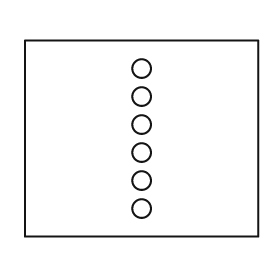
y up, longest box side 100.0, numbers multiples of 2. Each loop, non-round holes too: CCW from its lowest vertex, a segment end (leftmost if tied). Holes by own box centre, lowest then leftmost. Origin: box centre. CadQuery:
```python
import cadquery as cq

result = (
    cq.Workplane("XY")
    .moveTo(-50.0, -42.0)
    .lineTo(50.0, -42.0)
    .lineTo(50.0, 42.0)
    .lineTo(-50.0, 42.0)
    .close()
    .moveTo(0.0, -30.0)
    .circle(4.0)
    .moveTo(0.0, -18.0)
    .circle(4.0)
    .moveTo(0.0, -6.0)
    .circle(4.0)
    .moveTo(0.0, 6.0)
    .circle(4.0)
    .moveTo(0.0, 18.0)
    .circle(4.0)
    .moveTo(0.0, 30.0)
    .circle(4.0)
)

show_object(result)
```